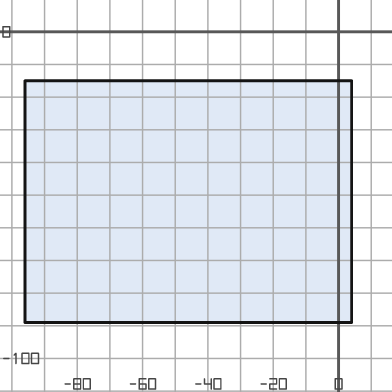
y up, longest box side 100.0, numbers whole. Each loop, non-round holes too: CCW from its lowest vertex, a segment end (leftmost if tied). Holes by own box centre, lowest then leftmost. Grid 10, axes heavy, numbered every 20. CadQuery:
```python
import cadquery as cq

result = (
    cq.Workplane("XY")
    .moveTo(-96.0, -89.0)
    .lineTo(4.0, -89.0)
    .lineTo(4.0, -15.0)
    .lineTo(-96.0, -15.0)
    .close()
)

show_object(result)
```